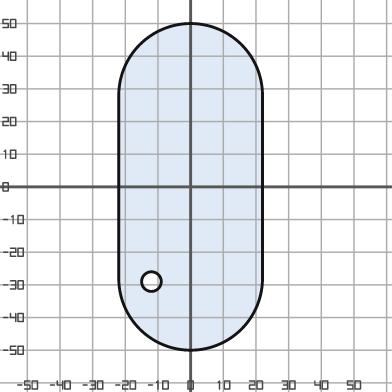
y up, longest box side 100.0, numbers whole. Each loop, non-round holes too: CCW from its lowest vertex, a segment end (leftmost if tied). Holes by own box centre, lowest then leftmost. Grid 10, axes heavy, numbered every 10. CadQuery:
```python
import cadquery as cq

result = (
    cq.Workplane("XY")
    .moveTo(-22.0, -28.0)
    .threePointArc((0.0, -50.0), (22.0, -28.0))
    .lineTo(22.0, 28.0)
    .threePointArc((0.0, 50.0), (-22.0, 28.0))
    .close()
    .moveTo(-12.0, -29.0)
    .circle(3.0)
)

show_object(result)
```